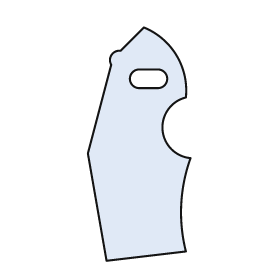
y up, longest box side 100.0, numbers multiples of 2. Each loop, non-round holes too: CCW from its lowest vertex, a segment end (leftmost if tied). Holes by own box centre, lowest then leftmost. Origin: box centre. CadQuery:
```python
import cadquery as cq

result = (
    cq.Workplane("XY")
    .moveTo(-14.0, -50.0)
    .lineTo(20.0, -46.0)
    .threePointArc((18.0, -26.0), (22.0, -6.0))
    .threePointArc((10.0, 6.0), (20.0, 20.0))
    .threePointArc((16.0, 38.0), (2.0, 50.0))
    .lineTo(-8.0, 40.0)
    .threePointArc((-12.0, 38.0), (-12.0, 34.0))
    .lineTo(-22.0, -4.0)
    .close()
    .moveTo(0.0, 24.0)
    .lineTo(8.0, 24.0)
    .threePointArc((12.0, 28.0), (8.0, 32.0))
    .lineTo(0.0, 32.0)
    .threePointArc((-4.0, 28.0), (0.0, 24.0))
    .close()
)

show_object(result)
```